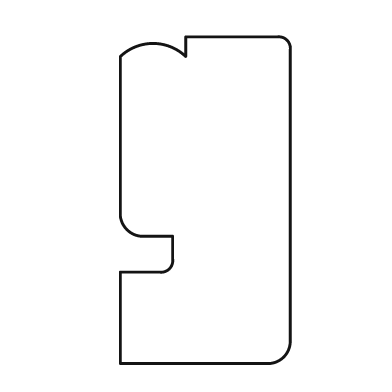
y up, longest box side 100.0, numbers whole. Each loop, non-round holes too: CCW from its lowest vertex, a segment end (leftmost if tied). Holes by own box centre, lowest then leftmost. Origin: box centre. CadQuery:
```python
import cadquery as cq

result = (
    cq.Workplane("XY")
    .moveTo(-26.0, -50.0)
    .lineTo(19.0, -50.0)
    .threePointArc((24.0, -48.0), (26.0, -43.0))
    .lineTo(26.0, 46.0)
    .threePointArc((25.0, 49.0), (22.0, 50.0))
    .lineTo(-6.0, 50.0)
    .lineTo(-6.0, 44.0)
    .threePointArc((-16.0, 48.0), (-26.0, 44.0))
    .lineTo(-26.0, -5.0)
    .threePointArc((-24.0, -9.0), (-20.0, -11.0))
    .lineTo(-10.0, -11.0)
    .lineTo(-10.0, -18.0)
    .threePointArc((-11.0, -21.0), (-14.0, -22.0))
    .lineTo(-26.0, -22.0)
    .close()
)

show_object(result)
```